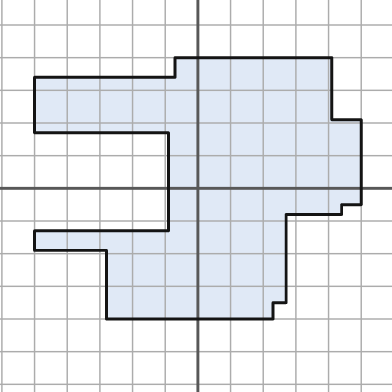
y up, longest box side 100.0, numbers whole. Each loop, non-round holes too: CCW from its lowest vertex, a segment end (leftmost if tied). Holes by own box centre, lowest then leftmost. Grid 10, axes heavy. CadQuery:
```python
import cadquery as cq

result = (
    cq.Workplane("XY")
    .moveTo(-28.0, -40.0)
    .lineTo(23.0, -40.0)
    .lineTo(23.0, -35.0)
    .lineTo(27.0, -35.0)
    .lineTo(27.0, -8.0)
    .lineTo(44.0, -8.0)
    .lineTo(44.0, -5.0)
    .lineTo(50.0, -5.0)
    .lineTo(50.0, 21.0)
    .lineTo(41.0, 21.0)
    .lineTo(41.0, 40.0)
    .lineTo(-7.0, 40.0)
    .lineTo(-7.0, 34.0)
    .lineTo(-50.0, 34.0)
    .lineTo(-50.0, 17.0)
    .lineTo(-9.0, 17.0)
    .lineTo(-9.0, -13.0)
    .lineTo(-50.0, -13.0)
    .lineTo(-50.0, -19.0)
    .lineTo(-28.0, -19.0)
    .close()
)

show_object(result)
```